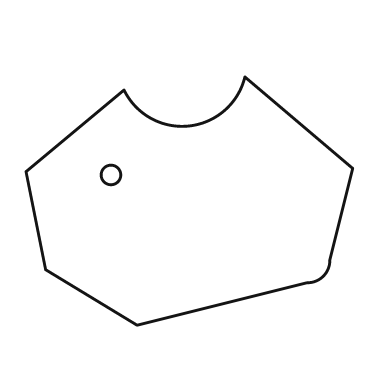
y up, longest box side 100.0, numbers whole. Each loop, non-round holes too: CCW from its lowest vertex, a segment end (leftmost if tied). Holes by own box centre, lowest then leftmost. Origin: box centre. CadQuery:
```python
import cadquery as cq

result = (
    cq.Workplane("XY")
    .moveTo(-16.0, -38.0)
    .lineTo(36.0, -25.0)
    .threePointArc((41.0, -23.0), (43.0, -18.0))
    .lineTo(50.0, 10.0)
    .lineTo(17.0, 38.0)
    .threePointArc((0.0, 23.0), (-20.0, 34.0))
    .lineTo(-50.0, 9.0)
    .lineTo(-44.0, -21.0)
    .close()
    .moveTo(-24.0, 8.0)
    .circle(3.0)
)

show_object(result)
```